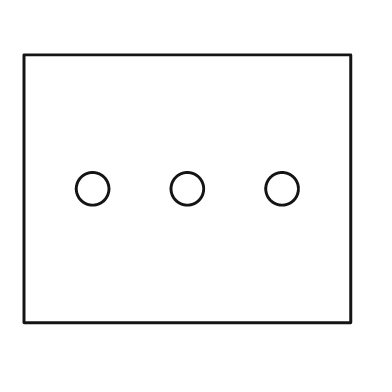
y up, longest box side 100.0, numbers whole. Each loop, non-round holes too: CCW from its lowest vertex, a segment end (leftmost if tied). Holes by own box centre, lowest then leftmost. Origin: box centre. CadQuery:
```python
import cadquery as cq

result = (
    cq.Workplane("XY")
    .moveTo(-50.0, -41.0)
    .lineTo(50.0, -41.0)
    .lineTo(50.0, 41.0)
    .lineTo(-50.0, 41.0)
    .close()
    .moveTo(-29.0, 0.0)
    .circle(5.0)
    .moveTo(0.0, 0.0)
    .circle(5.0)
    .moveTo(29.0, 0.0)
    .circle(5.0)
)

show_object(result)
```